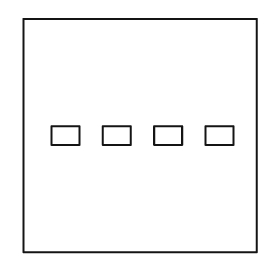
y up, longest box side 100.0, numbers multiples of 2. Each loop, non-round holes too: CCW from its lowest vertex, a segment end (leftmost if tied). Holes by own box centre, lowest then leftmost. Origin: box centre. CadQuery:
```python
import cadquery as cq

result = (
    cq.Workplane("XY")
    .moveTo(-50.0, -50.0)
    .lineTo(50.0, -50.0)
    .lineTo(50.0, 50.0)
    .lineTo(-50.0, 50.0)
    .close()
    .moveTo(-38.0, -4.0)
    .lineTo(-26.0, -4.0)
    .lineTo(-26.0, 4.0)
    .lineTo(-38.0, 4.0)
    .close()
    .moveTo(-16.0, -4.0)
    .lineTo(-4.0, -4.0)
    .lineTo(-4.0, 4.0)
    .lineTo(-16.0, 4.0)
    .close()
    .moveTo(6.0, -4.0)
    .lineTo(18.0, -4.0)
    .lineTo(18.0, 4.0)
    .lineTo(6.0, 4.0)
    .close()
    .moveTo(28.0, -4.0)
    .lineTo(40.0, -4.0)
    .lineTo(40.0, 4.0)
    .lineTo(28.0, 4.0)
    .close()
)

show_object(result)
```